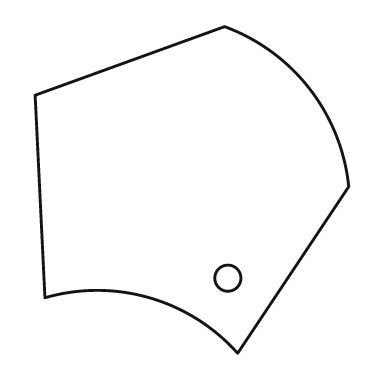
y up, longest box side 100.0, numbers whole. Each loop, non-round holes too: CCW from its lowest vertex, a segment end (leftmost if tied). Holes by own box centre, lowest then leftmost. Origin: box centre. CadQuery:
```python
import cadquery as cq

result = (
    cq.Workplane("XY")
    .moveTo(14.0, -50.0)
    .lineTo(48.0, 1.0)
    .threePointArc((36.0, 31.0), (10.0, 50.0))
    .lineTo(-48.0, 29.0)
    .lineTo(-45.0, -33.0)
    .threePointArc((-13.0, -33.0), (14.0, -50.0))
    .close()
    .moveTo(11.0, -27.0)
    .circle(4.0)
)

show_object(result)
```